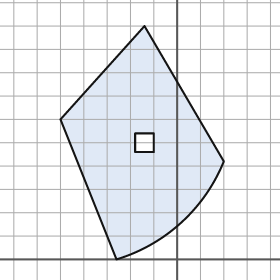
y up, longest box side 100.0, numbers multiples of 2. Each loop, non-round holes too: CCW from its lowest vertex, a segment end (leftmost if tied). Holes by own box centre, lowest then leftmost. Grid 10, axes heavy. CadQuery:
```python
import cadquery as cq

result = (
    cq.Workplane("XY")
    .moveTo(-26.0, 0.0)
    .threePointArc((2.0, 16.0), (20.0, 42.0))
    .lineTo(-14.0, 100.0)
    .lineTo(-50.0, 60.0)
    .close()
    .moveTo(-18.0, 46.0)
    .lineTo(-10.0, 46.0)
    .lineTo(-10.0, 54.0)
    .lineTo(-18.0, 54.0)
    .close()
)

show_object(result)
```